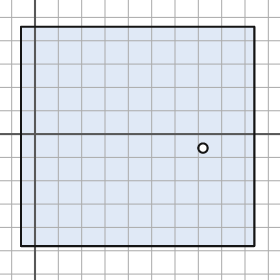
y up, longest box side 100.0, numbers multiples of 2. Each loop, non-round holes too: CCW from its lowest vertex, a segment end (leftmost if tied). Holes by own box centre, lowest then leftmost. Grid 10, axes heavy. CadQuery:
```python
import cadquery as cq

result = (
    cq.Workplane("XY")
    .moveTo(-6.0, -48.0)
    .lineTo(94.0, -48.0)
    .lineTo(94.0, 46.0)
    .lineTo(-6.0, 46.0)
    .close()
    .moveTo(72.0, -6.0)
    .circle(2.0)
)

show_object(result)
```